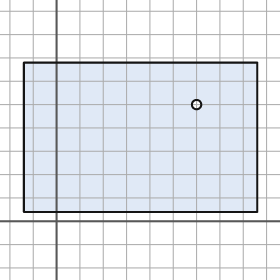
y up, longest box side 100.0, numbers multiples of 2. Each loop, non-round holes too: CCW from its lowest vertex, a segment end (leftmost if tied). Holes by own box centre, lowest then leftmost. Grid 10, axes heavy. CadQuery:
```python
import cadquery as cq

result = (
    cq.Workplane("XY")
    .moveTo(-14.0, 4.0)
    .lineTo(86.0, 4.0)
    .lineTo(86.0, 68.0)
    .lineTo(-14.0, 68.0)
    .close()
    .moveTo(60.0, 50.0)
    .circle(2.0)
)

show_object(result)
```